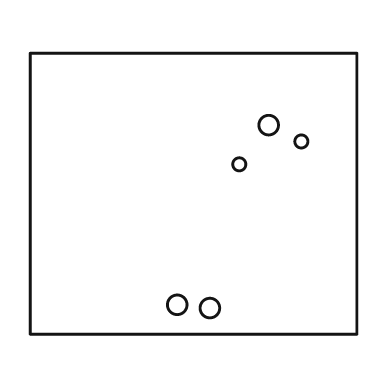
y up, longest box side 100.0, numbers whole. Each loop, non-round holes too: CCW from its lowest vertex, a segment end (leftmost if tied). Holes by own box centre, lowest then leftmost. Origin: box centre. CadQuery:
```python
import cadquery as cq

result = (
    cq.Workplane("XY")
    .moveTo(-50.0, -43.0)
    .lineTo(50.0, -43.0)
    .lineTo(50.0, 43.0)
    .lineTo(-50.0, 43.0)
    .close()
    .moveTo(5.0, -35.0)
    .circle(3.0)
    .moveTo(-5.0, -34.0)
    .circle(3.0)
    .moveTo(14.0, 9.0)
    .circle(2.0)
    .moveTo(33.0, 16.0)
    .circle(2.0)
    .moveTo(23.0, 21.0)
    .circle(3.0)
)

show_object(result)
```